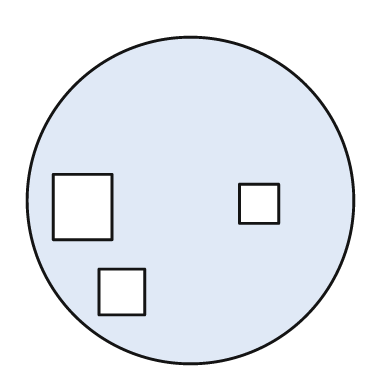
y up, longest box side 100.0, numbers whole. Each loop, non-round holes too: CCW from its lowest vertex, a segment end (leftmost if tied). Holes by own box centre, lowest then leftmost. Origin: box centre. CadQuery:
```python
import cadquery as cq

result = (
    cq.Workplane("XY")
    .moveTo(0.0, 0.0)
    .circle(50.0)
    .moveTo(-28.0, -35.0)
    .lineTo(-14.0, -35.0)
    .lineTo(-14.0, -21.0)
    .lineTo(-28.0, -21.0)
    .close()
    .moveTo(-42.0, -12.0)
    .lineTo(-24.0, -12.0)
    .lineTo(-24.0, 8.0)
    .lineTo(-42.0, 8.0)
    .close()
    .moveTo(15.0, -7.0)
    .lineTo(27.0, -7.0)
    .lineTo(27.0, 5.0)
    .lineTo(15.0, 5.0)
    .close()
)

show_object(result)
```